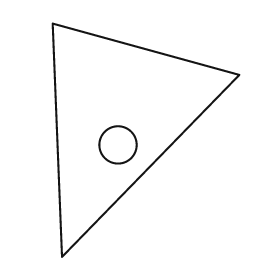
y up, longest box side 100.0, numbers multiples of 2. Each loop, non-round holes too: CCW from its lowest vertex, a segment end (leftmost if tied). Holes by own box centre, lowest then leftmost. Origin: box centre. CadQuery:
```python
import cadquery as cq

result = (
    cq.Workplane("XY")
    .moveTo(-36.0, -50.0)
    .lineTo(40.0, 28.0)
    .lineTo(-40.0, 50.0)
    .close()
    .moveTo(-12.0, -2.0)
    .circle(8.0)
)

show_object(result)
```